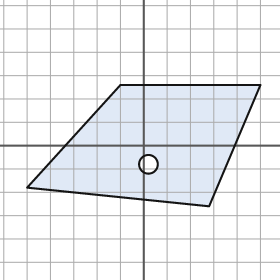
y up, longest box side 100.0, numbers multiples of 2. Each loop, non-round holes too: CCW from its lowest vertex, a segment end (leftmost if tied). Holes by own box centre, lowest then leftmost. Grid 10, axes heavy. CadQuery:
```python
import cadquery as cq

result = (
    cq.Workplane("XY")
    .moveTo(28.0, -26.0)
    .lineTo(50.0, 26.0)
    .lineTo(-10.0, 26.0)
    .lineTo(-50.0, -18.0)
    .close()
    .moveTo(2.0, -8.0)
    .circle(4.0)
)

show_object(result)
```